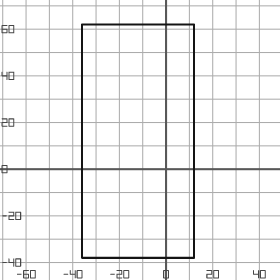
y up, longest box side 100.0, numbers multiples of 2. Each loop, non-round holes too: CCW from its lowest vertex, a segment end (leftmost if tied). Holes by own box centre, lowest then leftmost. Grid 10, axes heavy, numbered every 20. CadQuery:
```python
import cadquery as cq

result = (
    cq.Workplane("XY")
    .moveTo(-36.0, -38.0)
    .lineTo(12.0, -38.0)
    .lineTo(12.0, 62.0)
    .lineTo(-36.0, 62.0)
    .close()
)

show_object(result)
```